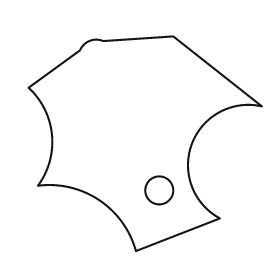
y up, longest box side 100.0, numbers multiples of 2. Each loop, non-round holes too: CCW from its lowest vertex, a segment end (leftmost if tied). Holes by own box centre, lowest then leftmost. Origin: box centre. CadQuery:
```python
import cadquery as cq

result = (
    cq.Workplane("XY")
    .moveTo(-4.0, -46.0)
    .lineTo(32.0, -32.0)
    .threePointArc((20.0, 0.0), (50.0, 16.0))
    .lineTo(12.0, 46.0)
    .lineTo(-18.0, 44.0)
    .threePointArc((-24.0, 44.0), (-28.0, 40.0))
    .lineTo(-50.0, 24.0)
    .threePointArc((-40.0, 4.0), (-46.0, -18.0))
    .threePointArc((-20.0, -24.0), (-4.0, -46.0))
    .close()
    .moveTo(6.0, -20.0)
    .circle(6.0)
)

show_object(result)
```